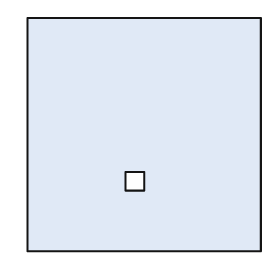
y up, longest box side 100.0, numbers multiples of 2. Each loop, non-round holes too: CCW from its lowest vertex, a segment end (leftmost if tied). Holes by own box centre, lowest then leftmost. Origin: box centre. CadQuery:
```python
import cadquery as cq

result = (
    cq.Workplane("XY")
    .moveTo(-50.0, -50.0)
    .lineTo(50.0, -50.0)
    .lineTo(50.0, 50.0)
    .lineTo(-50.0, 50.0)
    .close()
    .moveTo(-8.0, -24.0)
    .lineTo(0.0, -24.0)
    .lineTo(0.0, -16.0)
    .lineTo(-8.0, -16.0)
    .close()
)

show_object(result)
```